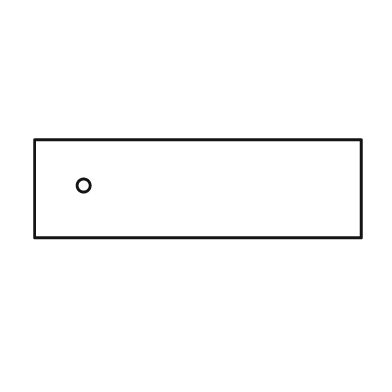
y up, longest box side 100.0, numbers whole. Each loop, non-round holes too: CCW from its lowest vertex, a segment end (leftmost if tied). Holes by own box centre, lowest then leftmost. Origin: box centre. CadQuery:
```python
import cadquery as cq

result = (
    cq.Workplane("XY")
    .moveTo(-50.0, -15.0)
    .lineTo(50.0, -15.0)
    .lineTo(50.0, 15.0)
    .lineTo(-50.0, 15.0)
    .close()
    .moveTo(-35.0, 1.0)
    .circle(2.0)
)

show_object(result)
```